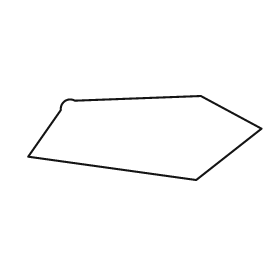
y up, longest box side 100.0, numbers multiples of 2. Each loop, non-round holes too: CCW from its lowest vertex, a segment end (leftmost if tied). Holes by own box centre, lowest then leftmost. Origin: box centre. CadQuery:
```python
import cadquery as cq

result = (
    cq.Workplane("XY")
    .moveTo(22.0, -18.0)
    .lineTo(50.0, 4.0)
    .lineTo(24.0, 18.0)
    .lineTo(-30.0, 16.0)
    .threePointArc((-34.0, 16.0), (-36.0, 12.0))
    .lineTo(-50.0, -8.0)
    .close()
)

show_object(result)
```